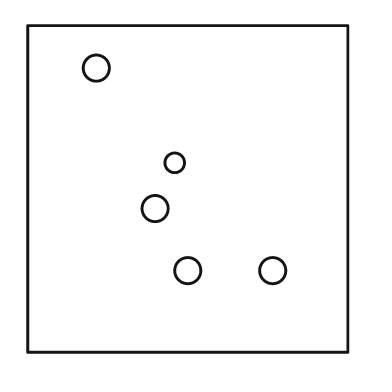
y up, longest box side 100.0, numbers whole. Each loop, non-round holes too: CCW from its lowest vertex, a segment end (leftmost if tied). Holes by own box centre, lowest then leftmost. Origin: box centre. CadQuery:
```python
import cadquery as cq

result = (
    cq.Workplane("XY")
    .moveTo(-49.0, -50.0)
    .lineTo(49.0, -50.0)
    .lineTo(49.0, 50.0)
    .lineTo(-49.0, 50.0)
    .close()
    .moveTo(0.0, -25.0)
    .circle(4.0)
    .moveTo(26.0, -25.0)
    .circle(4.0)
    .moveTo(-10.0, -6.0)
    .circle(4.0)
    .moveTo(-4.0, 8.0)
    .circle(3.0)
    .moveTo(-28.0, 37.0)
    .circle(4.0)
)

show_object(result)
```